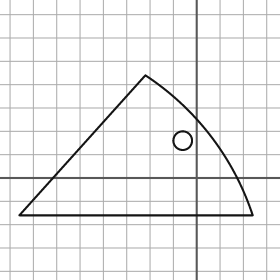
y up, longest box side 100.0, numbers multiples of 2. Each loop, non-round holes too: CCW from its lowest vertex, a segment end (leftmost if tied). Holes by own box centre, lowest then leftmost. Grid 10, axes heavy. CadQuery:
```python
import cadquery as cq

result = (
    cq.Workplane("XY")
    .moveTo(-76.0, -16.0)
    .lineTo(24.0, -16.0)
    .threePointArc((6.0, 18.0), (-22.0, 44.0))
    .close()
    .moveTo(-6.0, 16.0)
    .circle(4.0)
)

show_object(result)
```